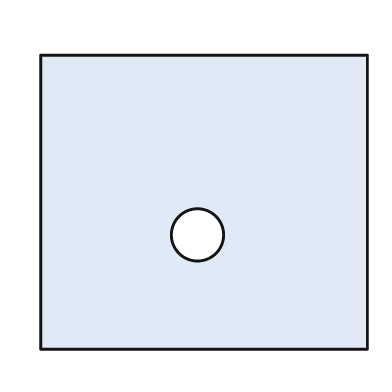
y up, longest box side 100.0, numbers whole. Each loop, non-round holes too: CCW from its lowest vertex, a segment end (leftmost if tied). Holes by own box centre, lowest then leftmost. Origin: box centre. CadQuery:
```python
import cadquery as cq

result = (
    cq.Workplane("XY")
    .moveTo(-50.0, -45.0)
    .lineTo(50.0, -45.0)
    .lineTo(50.0, 45.0)
    .lineTo(-50.0, 45.0)
    .close()
    .moveTo(-2.0, -10.0)
    .circle(8.0)
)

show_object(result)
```